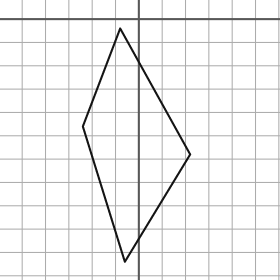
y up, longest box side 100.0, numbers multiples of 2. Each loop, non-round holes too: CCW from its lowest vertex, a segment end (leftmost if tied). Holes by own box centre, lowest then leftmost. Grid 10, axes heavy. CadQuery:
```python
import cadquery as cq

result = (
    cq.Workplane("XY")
    .moveTo(-6.0, -104.0)
    .lineTo(22.0, -58.0)
    .lineTo(-8.0, -4.0)
    .lineTo(-24.0, -46.0)
    .close()
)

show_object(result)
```